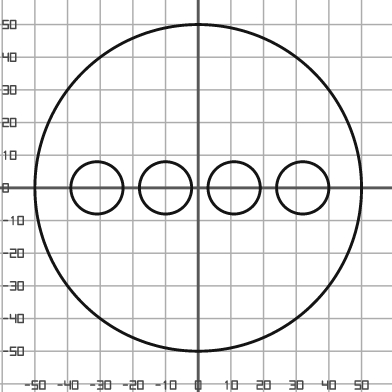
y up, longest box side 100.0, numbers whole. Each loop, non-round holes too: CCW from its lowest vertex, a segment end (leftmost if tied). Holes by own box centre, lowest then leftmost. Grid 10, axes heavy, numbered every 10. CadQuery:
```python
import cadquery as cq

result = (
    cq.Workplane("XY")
    .moveTo(0.0, 0.0)
    .circle(50.0)
    .moveTo(-31.0, 0.0)
    .circle(8.0)
    .moveTo(-10.0, 0.0)
    .circle(8.0)
    .moveTo(11.0, 0.0)
    .circle(8.0)
    .moveTo(32.0, 0.0)
    .circle(8.0)
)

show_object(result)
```